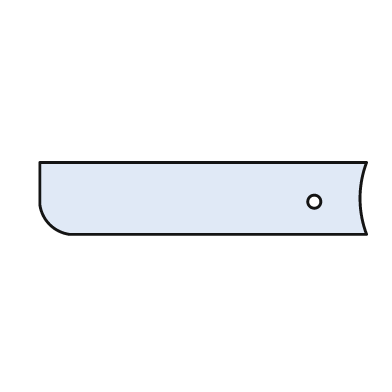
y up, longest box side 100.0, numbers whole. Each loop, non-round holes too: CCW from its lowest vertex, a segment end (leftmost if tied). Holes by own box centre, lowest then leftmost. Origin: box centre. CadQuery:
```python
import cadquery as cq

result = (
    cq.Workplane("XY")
    .moveTo(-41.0, -11.0)
    .lineTo(50.0, -11.0)
    .threePointArc((48.0, 0.0), (50.0, 11.0))
    .lineTo(-50.0, 11.0)
    .lineTo(-50.0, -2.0)
    .threePointArc((-47.0, -8.0), (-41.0, -11.0))
    .close()
    .moveTo(34.0, -1.0)
    .circle(2.0)
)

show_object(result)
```